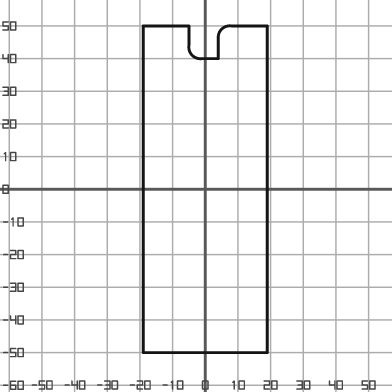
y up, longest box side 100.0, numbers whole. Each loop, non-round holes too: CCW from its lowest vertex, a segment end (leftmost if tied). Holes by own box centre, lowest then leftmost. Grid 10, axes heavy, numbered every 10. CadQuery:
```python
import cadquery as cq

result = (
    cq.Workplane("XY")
    .moveTo(-19.0, -50.0)
    .lineTo(19.0, -50.0)
    .lineTo(19.0, 50.0)
    .lineTo(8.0, 50.0)
    .threePointArc((5.0, 49.0), (4.0, 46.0))
    .lineTo(4.0, 40.0)
    .lineTo(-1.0, 40.0)
    .threePointArc((-4.0, 41.0), (-5.0, 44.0))
    .lineTo(-5.0, 50.0)
    .lineTo(-19.0, 50.0)
    .close()
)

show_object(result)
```